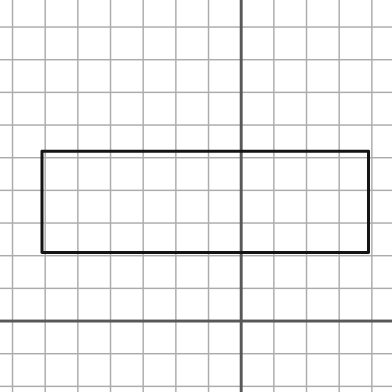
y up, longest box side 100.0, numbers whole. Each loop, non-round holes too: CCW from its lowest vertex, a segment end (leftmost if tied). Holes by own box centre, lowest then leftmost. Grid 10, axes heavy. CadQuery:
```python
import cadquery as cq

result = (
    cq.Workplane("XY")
    .moveTo(-61.0, 21.0)
    .lineTo(39.0, 21.0)
    .lineTo(39.0, 52.0)
    .lineTo(-61.0, 52.0)
    .close()
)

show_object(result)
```